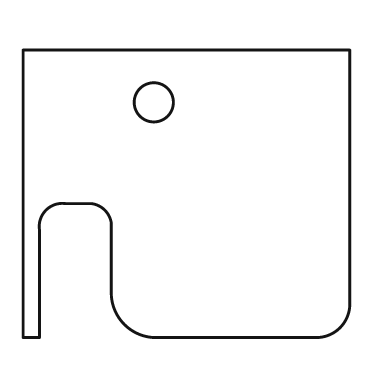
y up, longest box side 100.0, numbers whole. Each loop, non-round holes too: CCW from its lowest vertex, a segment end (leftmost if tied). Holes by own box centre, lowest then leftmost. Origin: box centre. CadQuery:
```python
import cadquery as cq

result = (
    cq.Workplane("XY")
    .moveTo(-50.0, -44.0)
    .lineTo(-45.0, -44.0)
    .lineTo(-45.0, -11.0)
    .threePointArc((-43.0, -5.0), (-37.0, -3.0))
    .lineTo(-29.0, -3.0)
    .threePointArc((-25.0, -5.0), (-23.0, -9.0))
    .lineTo(-23.0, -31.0)
    .threePointArc((-19.0, -40.0), (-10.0, -44.0))
    .lineTo(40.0, -44.0)
    .threePointArc((47.0, -41.0), (50.0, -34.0))
    .lineTo(50.0, 44.0)
    .lineTo(-50.0, 44.0)
    .close()
    .moveTo(-10.0, 28.0)
    .circle(6.0)
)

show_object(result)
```